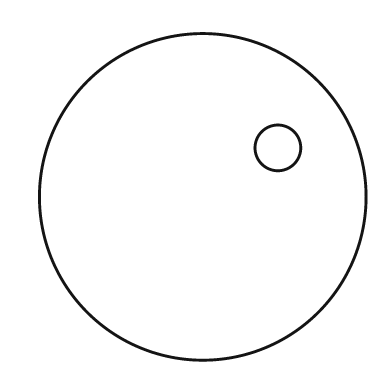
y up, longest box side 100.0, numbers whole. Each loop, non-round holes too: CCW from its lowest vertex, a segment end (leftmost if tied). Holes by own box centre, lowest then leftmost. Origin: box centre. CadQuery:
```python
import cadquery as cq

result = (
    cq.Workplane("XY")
    .moveTo(0.0, 0.0)
    .circle(50.0)
    .moveTo(23.0, 15.0)
    .circle(7.0)
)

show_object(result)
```